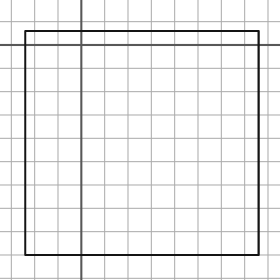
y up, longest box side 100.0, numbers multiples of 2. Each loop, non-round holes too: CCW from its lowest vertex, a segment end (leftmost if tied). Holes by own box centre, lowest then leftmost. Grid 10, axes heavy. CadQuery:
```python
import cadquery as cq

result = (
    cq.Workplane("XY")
    .moveTo(-24.0, -90.0)
    .lineTo(76.0, -90.0)
    .lineTo(76.0, 6.0)
    .lineTo(-24.0, 6.0)
    .close()
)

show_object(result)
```